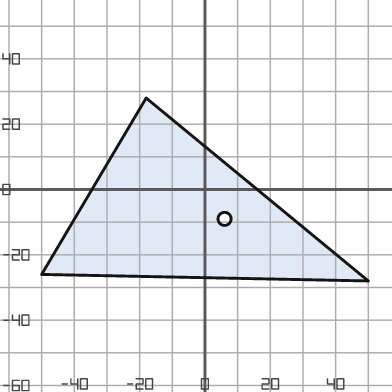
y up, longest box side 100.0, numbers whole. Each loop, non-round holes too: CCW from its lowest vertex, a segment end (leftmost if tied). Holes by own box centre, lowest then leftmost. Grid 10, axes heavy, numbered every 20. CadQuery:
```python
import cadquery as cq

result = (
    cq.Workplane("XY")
    .moveTo(50.0, -28.0)
    .lineTo(-18.0, 28.0)
    .lineTo(-50.0, -26.0)
    .close()
    .moveTo(6.0, -9.0)
    .circle(2.0)
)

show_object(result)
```